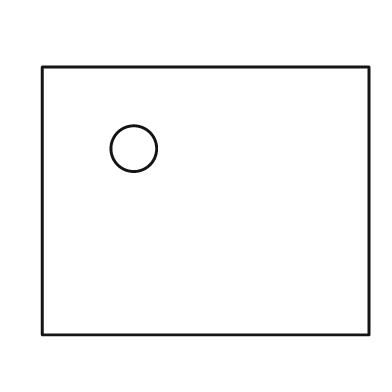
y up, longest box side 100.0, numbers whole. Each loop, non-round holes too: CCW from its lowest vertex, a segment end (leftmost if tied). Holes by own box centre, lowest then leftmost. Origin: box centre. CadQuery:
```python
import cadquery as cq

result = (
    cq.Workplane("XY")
    .moveTo(-50.0, -41.0)
    .lineTo(50.0, -41.0)
    .lineTo(50.0, 41.0)
    .lineTo(-50.0, 41.0)
    .close()
    .moveTo(-22.0, 16.0)
    .circle(7.0)
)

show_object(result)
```